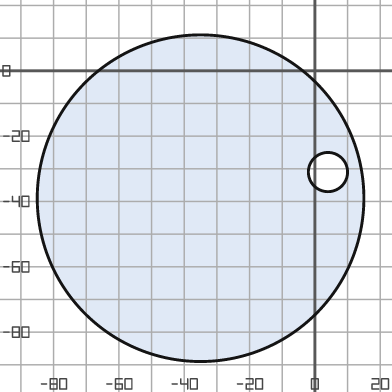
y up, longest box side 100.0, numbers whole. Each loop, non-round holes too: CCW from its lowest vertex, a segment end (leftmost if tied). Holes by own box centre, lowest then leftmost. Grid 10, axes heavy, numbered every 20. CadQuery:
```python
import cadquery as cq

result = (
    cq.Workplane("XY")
    .moveTo(-35.0, -39.0)
    .circle(50.0)
    .moveTo(4.0, -31.0)
    .circle(6.0)
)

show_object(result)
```